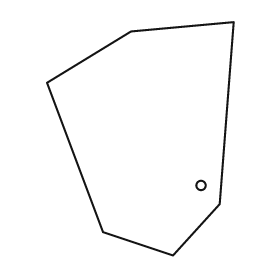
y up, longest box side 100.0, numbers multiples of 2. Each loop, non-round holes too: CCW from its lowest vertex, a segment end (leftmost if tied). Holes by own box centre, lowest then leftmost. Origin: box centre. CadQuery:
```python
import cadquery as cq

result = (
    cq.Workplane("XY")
    .moveTo(14.0, -50.0)
    .lineTo(34.0, -28.0)
    .lineTo(40.0, 50.0)
    .lineTo(-4.0, 46.0)
    .lineTo(-40.0, 24.0)
    .lineTo(-16.0, -40.0)
    .close()
    .moveTo(26.0, -20.0)
    .circle(2.0)
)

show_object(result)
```